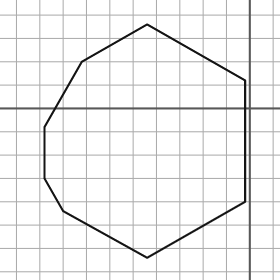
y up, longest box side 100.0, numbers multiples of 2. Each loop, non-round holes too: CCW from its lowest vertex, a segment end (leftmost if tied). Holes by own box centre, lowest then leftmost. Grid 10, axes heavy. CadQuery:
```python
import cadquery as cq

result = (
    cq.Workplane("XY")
    .moveTo(-44.0, -64.0)
    .lineTo(-2.0, -40.0)
    .lineTo(-2.0, 12.0)
    .lineTo(-44.0, 36.0)
    .lineTo(-72.0, 20.0)
    .lineTo(-88.0, -8.0)
    .lineTo(-88.0, -30.0)
    .lineTo(-80.0, -44.0)
    .close()
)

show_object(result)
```